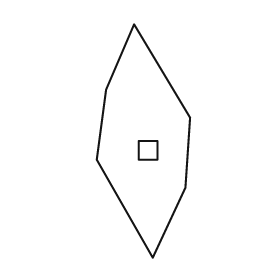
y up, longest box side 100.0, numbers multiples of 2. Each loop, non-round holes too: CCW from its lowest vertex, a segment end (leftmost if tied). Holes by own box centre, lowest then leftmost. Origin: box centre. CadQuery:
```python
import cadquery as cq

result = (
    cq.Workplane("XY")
    .moveTo(4.0, -50.0)
    .lineTo(18.0, -20.0)
    .lineTo(20.0, 10.0)
    .lineTo(-4.0, 50.0)
    .lineTo(-16.0, 22.0)
    .lineTo(-20.0, -8.0)
    .close()
    .moveTo(-2.0, -8.0)
    .lineTo(6.0, -8.0)
    .lineTo(6.0, 0.0)
    .lineTo(-2.0, 0.0)
    .close()
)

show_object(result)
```